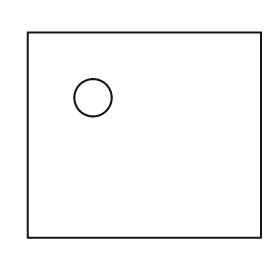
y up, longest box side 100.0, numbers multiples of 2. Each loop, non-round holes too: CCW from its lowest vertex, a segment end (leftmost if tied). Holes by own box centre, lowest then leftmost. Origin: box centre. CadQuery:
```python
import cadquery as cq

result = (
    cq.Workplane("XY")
    .moveTo(-50.0, -44.0)
    .lineTo(50.0, -44.0)
    .lineTo(50.0, 44.0)
    .lineTo(-50.0, 44.0)
    .close()
    .moveTo(-22.0, 16.0)
    .circle(8.0)
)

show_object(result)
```